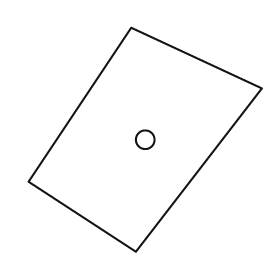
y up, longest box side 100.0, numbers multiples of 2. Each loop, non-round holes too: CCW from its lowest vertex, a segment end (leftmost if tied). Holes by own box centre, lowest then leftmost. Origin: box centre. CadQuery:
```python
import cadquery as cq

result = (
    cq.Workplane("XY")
    .moveTo(-4.0, -48.0)
    .lineTo(50.0, 22.0)
    .lineTo(-6.0, 48.0)
    .lineTo(-50.0, -18.0)
    .close()
    .moveTo(0.0, 0.0)
    .circle(4.0)
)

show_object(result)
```